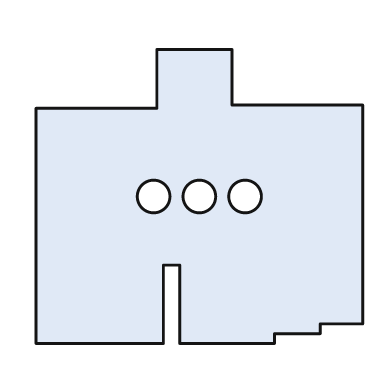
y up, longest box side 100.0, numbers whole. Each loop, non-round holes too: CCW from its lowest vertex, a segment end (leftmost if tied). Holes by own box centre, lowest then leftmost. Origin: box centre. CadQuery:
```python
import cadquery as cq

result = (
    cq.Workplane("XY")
    .moveTo(-50.0, -45.0)
    .lineTo(-11.0, -45.0)
    .lineTo(-11.0, -21.0)
    .lineTo(-6.0, -21.0)
    .lineTo(-6.0, -45.0)
    .lineTo(23.0, -45.0)
    .lineTo(23.0, -42.0)
    .lineTo(37.0, -42.0)
    .lineTo(37.0, -39.0)
    .lineTo(50.0, -39.0)
    .lineTo(50.0, 28.0)
    .lineTo(10.0, 28.0)
    .lineTo(10.0, 45.0)
    .lineTo(-13.0, 45.0)
    .lineTo(-13.0, 27.0)
    .lineTo(-50.0, 27.0)
    .close()
    .moveTo(-14.0, 0.0)
    .circle(5.0)
    .moveTo(0.0, 0.0)
    .circle(5.0)
    .moveTo(14.0, 0.0)
    .circle(5.0)
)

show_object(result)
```